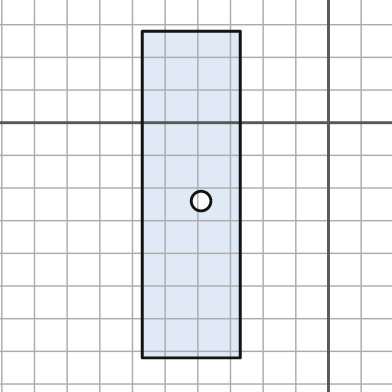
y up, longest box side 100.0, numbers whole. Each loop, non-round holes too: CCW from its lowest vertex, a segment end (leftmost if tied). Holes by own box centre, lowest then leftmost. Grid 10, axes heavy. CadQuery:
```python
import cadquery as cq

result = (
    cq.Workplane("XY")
    .moveTo(-57.0, -72.0)
    .lineTo(-27.0, -72.0)
    .lineTo(-27.0, 28.0)
    .lineTo(-57.0, 28.0)
    .close()
    .moveTo(-39.0, -24.0)
    .circle(3.0)
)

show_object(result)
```